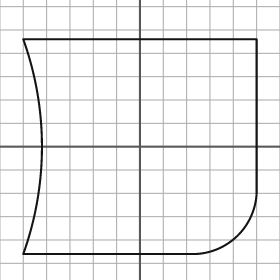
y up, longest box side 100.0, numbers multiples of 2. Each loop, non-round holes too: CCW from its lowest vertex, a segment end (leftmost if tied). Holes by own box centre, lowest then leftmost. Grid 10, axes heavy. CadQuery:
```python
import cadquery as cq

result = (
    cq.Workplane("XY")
    .moveTo(-50.0, -46.0)
    .lineTo(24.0, -46.0)
    .threePointArc((42.0, -38.0), (50.0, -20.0))
    .lineTo(50.0, 46.0)
    .lineTo(-50.0, 46.0)
    .threePointArc((-42.0, 0.0), (-50.0, -46.0))
    .close()
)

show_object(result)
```